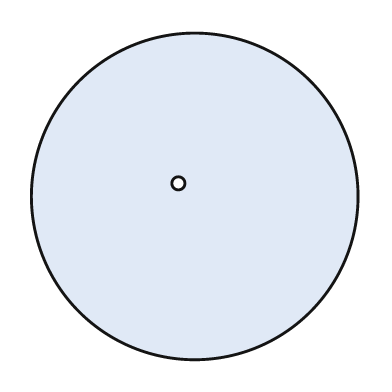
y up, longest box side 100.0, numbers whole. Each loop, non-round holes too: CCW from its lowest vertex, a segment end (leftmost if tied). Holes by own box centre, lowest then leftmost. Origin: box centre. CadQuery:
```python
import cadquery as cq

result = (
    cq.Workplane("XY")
    .moveTo(0.0, 0.0)
    .circle(50.0)
    .moveTo(-5.0, 4.0)
    .circle(2.0)
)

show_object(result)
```